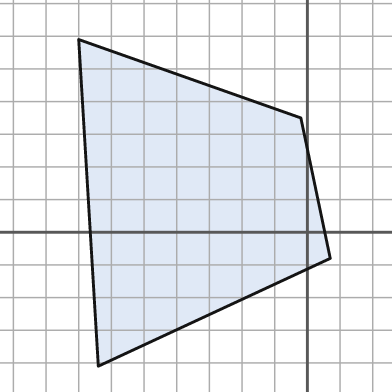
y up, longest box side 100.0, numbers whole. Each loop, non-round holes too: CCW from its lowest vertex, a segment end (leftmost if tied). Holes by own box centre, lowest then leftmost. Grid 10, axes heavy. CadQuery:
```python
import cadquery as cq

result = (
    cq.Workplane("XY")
    .moveTo(-64.0, -41.0)
    .lineTo(7.0, -8.0)
    .lineTo(-2.0, 35.0)
    .lineTo(-70.0, 59.0)
    .close()
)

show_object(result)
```